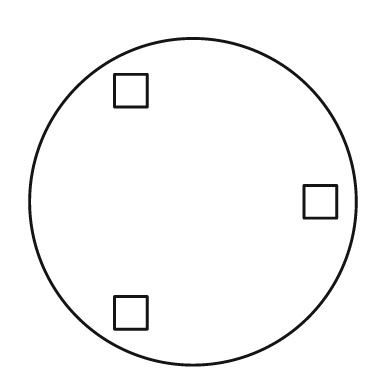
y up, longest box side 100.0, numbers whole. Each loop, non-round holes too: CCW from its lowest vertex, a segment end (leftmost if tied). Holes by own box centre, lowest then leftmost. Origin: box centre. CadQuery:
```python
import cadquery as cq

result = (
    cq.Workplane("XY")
    .moveTo(0.0, 0.0)
    .circle(50.0)
    .moveTo(-24.0, -39.0)
    .lineTo(-14.0, -39.0)
    .lineTo(-14.0, -29.0)
    .lineTo(-24.0, -29.0)
    .close()
    .moveTo(34.0, -5.0)
    .lineTo(44.0, -5.0)
    .lineTo(44.0, 5.0)
    .lineTo(34.0, 5.0)
    .close()
    .moveTo(-24.0, 29.0)
    .lineTo(-14.0, 29.0)
    .lineTo(-14.0, 39.0)
    .lineTo(-24.0, 39.0)
    .close()
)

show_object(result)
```